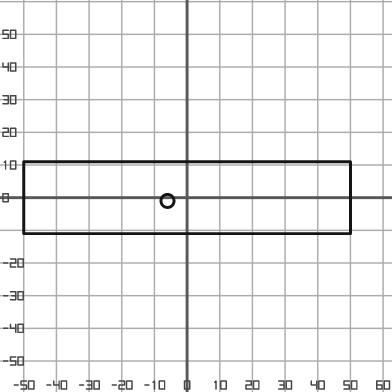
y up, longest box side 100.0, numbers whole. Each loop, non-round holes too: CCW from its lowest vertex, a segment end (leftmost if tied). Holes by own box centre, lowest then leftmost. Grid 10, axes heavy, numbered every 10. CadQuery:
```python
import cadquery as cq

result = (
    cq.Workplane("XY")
    .moveTo(-50.0, -11.0)
    .lineTo(50.0, -11.0)
    .lineTo(50.0, 11.0)
    .lineTo(-50.0, 11.0)
    .close()
    .moveTo(-6.0, -1.0)
    .circle(2.0)
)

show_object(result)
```